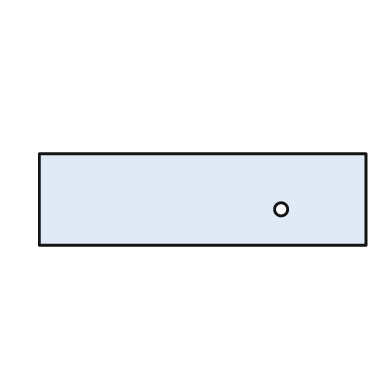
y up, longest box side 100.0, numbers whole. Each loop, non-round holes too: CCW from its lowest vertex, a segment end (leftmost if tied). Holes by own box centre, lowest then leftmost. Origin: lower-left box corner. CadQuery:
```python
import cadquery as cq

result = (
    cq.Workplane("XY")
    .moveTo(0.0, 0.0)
    .lineTo(100.0, 0.0)
    .lineTo(100.0, 28.0)
    .lineTo(0.0, 28.0)
    .close()
    .moveTo(74.0, 11.0)
    .circle(2.0)
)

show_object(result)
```